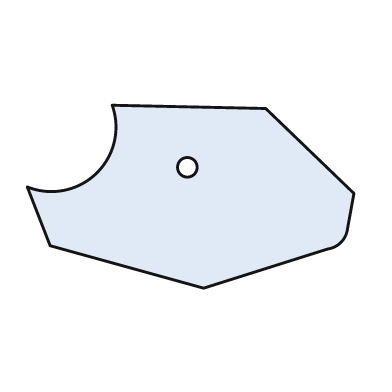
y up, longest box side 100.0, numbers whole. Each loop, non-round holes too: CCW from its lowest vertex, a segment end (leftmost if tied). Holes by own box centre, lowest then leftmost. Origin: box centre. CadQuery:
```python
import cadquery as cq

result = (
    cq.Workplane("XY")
    .moveTo(4.0, -28.0)
    .lineTo(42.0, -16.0)
    .threePointArc((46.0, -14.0), (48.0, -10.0))
    .lineTo(50.0, 1.0)
    .lineTo(23.0, 27.0)
    .lineTo(-24.0, 28.0)
    .threePointArc((-29.0, 7.0), (-50.0, 3.0))
    .lineTo(-43.0, -15.0)
    .close()
    .moveTo(-1.0, 9.0)
    .circle(3.0)
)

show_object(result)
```